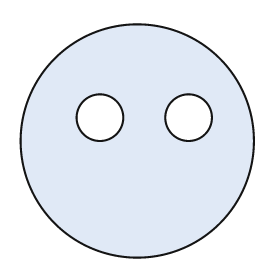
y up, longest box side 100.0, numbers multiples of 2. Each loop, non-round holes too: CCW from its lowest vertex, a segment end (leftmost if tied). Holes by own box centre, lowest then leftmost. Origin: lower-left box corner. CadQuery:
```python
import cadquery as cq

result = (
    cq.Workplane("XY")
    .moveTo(50.0, 50.0)
    .circle(50.0)
    .moveTo(34.0, 60.0)
    .circle(10.0)
    .moveTo(72.0, 60.0)
    .circle(10.0)
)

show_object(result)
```